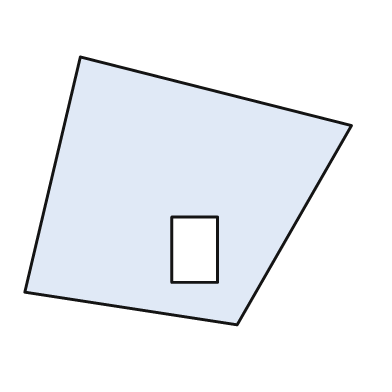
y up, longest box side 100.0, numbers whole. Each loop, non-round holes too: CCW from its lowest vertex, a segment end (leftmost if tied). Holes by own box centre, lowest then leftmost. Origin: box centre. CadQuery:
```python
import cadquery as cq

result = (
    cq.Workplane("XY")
    .moveTo(15.0, -41.0)
    .lineTo(50.0, 20.0)
    .lineTo(-33.0, 41.0)
    .lineTo(-50.0, -31.0)
    .close()
    .moveTo(-5.0, -28.0)
    .lineTo(9.0, -28.0)
    .lineTo(9.0, -8.0)
    .lineTo(-5.0, -8.0)
    .close()
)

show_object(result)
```